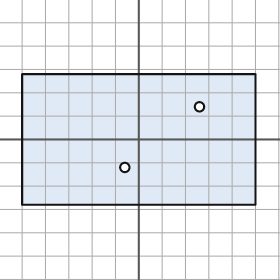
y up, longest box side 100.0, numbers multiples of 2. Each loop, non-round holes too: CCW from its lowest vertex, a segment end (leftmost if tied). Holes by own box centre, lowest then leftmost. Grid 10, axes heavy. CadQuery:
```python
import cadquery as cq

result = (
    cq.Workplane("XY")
    .moveTo(-50.0, -28.0)
    .lineTo(50.0, -28.0)
    .lineTo(50.0, 28.0)
    .lineTo(-50.0, 28.0)
    .close()
    .moveTo(-6.0, -12.0)
    .circle(2.0)
    .moveTo(26.0, 14.0)
    .circle(2.0)
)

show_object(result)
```